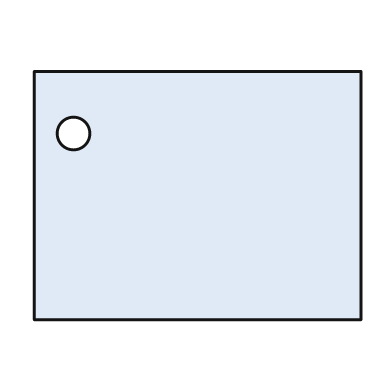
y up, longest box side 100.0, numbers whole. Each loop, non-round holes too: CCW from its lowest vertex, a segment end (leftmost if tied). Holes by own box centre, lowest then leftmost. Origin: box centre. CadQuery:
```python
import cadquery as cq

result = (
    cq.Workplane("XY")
    .moveTo(-50.0, -38.0)
    .lineTo(50.0, -38.0)
    .lineTo(50.0, 38.0)
    .lineTo(-50.0, 38.0)
    .close()
    .moveTo(-38.0, 19.0)
    .circle(5.0)
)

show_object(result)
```